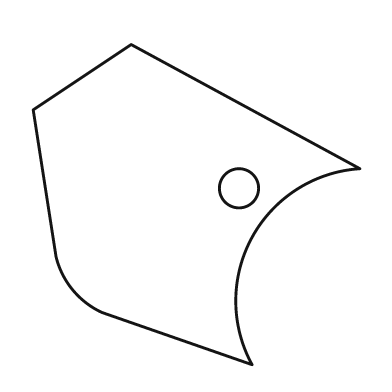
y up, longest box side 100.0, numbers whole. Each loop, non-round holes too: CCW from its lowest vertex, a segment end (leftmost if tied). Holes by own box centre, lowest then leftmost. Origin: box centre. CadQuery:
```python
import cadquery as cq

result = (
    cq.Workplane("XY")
    .moveTo(17.0, -49.0)
    .threePointArc((17.0, -10.0), (50.0, 11.0))
    .lineTo(-20.0, 49.0)
    .lineTo(-50.0, 29.0)
    .lineTo(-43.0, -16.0)
    .threePointArc((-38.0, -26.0), (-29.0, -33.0))
    .close()
    .moveTo(13.0, 5.0)
    .circle(6.0)
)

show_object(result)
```